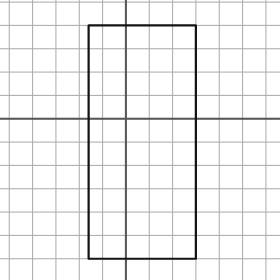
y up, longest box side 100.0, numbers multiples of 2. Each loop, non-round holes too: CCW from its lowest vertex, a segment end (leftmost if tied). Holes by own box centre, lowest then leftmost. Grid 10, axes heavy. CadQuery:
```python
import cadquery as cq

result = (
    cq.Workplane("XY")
    .moveTo(-16.0, -60.0)
    .lineTo(30.0, -60.0)
    .lineTo(30.0, 40.0)
    .lineTo(-16.0, 40.0)
    .close()
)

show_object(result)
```